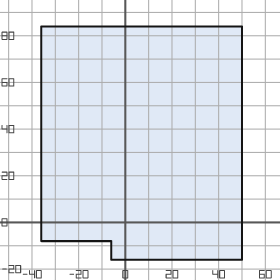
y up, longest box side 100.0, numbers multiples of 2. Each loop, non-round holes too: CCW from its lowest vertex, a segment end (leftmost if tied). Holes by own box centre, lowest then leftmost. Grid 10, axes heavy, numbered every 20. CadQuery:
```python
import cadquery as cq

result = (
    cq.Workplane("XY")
    .moveTo(-6.0, -16.0)
    .lineTo(50.0, -16.0)
    .lineTo(50.0, 84.0)
    .lineTo(-36.0, 84.0)
    .lineTo(-36.0, -8.0)
    .lineTo(-6.0, -8.0)
    .close()
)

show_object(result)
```